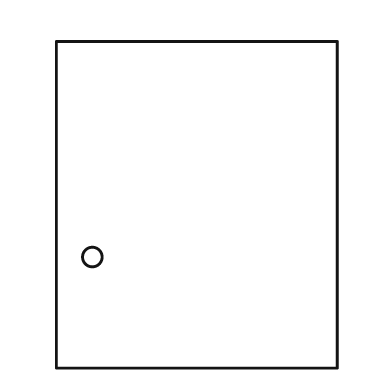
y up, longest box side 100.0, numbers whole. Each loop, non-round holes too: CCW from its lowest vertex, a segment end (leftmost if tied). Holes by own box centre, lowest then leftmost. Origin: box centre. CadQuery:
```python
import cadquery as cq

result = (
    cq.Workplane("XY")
    .moveTo(-43.0, -50.0)
    .lineTo(43.0, -50.0)
    .lineTo(43.0, 50.0)
    .lineTo(-43.0, 50.0)
    .close()
    .moveTo(-32.0, -16.0)
    .circle(3.0)
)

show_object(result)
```